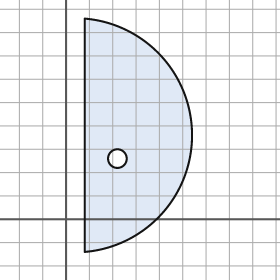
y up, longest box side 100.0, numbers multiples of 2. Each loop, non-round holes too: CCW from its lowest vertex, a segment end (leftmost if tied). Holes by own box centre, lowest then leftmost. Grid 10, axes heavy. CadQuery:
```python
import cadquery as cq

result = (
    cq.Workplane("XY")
    .moveTo(8.0, -14.0)
    .threePointArc((54.0, 36.0), (8.0, 86.0))
    .close()
    .moveTo(22.0, 26.0)
    .circle(4.0)
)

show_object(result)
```